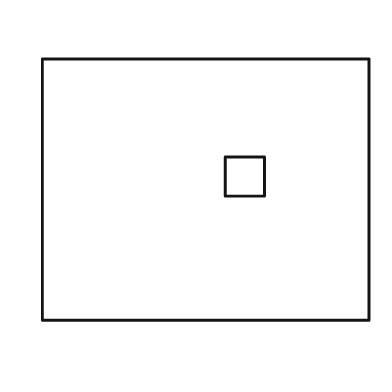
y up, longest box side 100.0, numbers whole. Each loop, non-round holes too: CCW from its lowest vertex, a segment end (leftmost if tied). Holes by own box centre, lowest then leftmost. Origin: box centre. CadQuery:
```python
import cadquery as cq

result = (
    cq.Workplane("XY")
    .moveTo(-50.0, -40.0)
    .lineTo(50.0, -40.0)
    .lineTo(50.0, 40.0)
    .lineTo(-50.0, 40.0)
    .close()
    .moveTo(6.0, -2.0)
    .lineTo(18.0, -2.0)
    .lineTo(18.0, 10.0)
    .lineTo(6.0, 10.0)
    .close()
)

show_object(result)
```